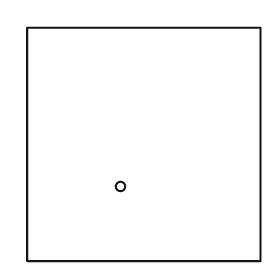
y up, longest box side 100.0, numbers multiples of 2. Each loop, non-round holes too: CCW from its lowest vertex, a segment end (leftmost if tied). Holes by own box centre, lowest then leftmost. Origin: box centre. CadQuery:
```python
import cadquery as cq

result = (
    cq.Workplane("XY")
    .moveTo(-50.0, -50.0)
    .lineTo(50.0, -50.0)
    .lineTo(50.0, 50.0)
    .lineTo(-50.0, 50.0)
    .close()
    .moveTo(-10.0, -18.0)
    .circle(2.0)
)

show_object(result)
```